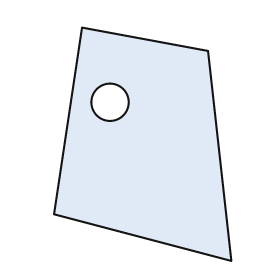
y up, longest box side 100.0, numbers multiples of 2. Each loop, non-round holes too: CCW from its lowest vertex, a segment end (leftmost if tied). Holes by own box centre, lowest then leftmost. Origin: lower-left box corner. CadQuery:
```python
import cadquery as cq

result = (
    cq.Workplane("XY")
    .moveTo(76.0, 0.0)
    .lineTo(66.0, 90.0)
    .lineTo(12.0, 100.0)
    .lineTo(0.0, 20.0)
    .close()
    .moveTo(24.0, 68.0)
    .circle(8.0)
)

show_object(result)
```